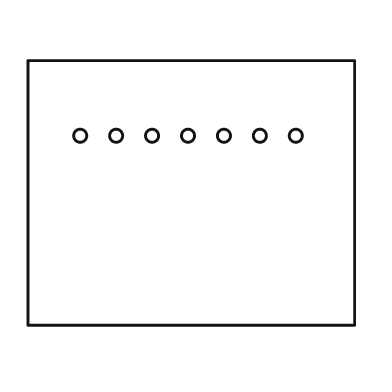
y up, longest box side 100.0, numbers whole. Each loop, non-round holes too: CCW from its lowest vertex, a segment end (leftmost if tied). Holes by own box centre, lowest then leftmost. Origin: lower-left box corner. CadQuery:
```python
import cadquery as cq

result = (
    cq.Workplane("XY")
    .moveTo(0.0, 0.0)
    .lineTo(100.0, 0.0)
    .lineTo(100.0, 81.0)
    .lineTo(0.0, 81.0)
    .close()
    .moveTo(16.0, 58.0)
    .circle(2.0)
    .moveTo(27.0, 58.0)
    .circle(2.0)
    .moveTo(38.0, 58.0)
    .circle(2.0)
    .moveTo(49.0, 58.0)
    .circle(2.0)
    .moveTo(60.0, 58.0)
    .circle(2.0)
    .moveTo(71.0, 58.0)
    .circle(2.0)
    .moveTo(82.0, 58.0)
    .circle(2.0)
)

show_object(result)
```